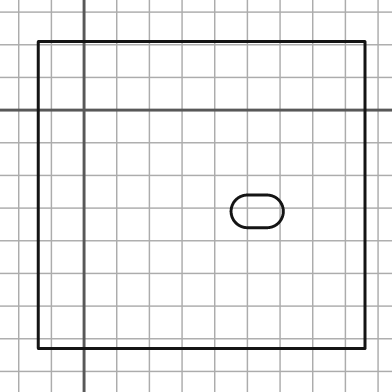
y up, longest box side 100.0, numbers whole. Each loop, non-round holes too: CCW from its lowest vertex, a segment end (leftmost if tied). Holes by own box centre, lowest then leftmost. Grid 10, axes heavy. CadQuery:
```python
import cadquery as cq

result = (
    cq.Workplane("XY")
    .moveTo(-14.0, -73.0)
    .lineTo(86.0, -73.0)
    .lineTo(86.0, 21.0)
    .lineTo(-14.0, 21.0)
    .close()
    .moveTo(50.0, -36.0)
    .lineTo(56.0, -36.0)
    .threePointArc((61.0, -31.0), (56.0, -26.0))
    .lineTo(50.0, -26.0)
    .threePointArc((45.0, -31.0), (50.0, -36.0))
    .close()
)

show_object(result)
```